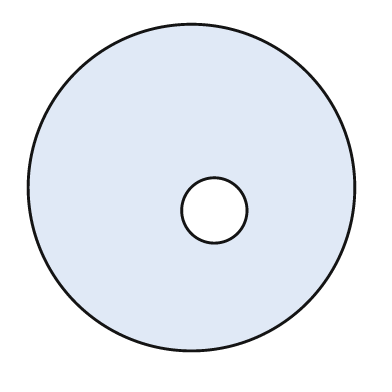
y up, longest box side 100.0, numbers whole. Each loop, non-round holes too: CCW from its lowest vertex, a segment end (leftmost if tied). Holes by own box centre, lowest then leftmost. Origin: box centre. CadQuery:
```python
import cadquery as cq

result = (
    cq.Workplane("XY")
    .moveTo(0.0, 0.0)
    .circle(50.0)
    .moveTo(7.0, -7.0)
    .circle(10.0)
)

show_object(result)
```